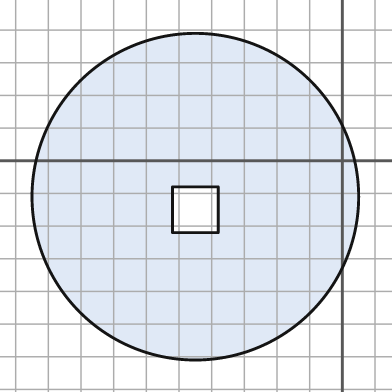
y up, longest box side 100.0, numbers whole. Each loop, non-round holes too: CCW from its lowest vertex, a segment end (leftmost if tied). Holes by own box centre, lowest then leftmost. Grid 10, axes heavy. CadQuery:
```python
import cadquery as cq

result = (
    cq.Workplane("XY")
    .moveTo(-45.0, -11.0)
    .circle(50.0)
    .moveTo(-52.0, -22.0)
    .lineTo(-38.0, -22.0)
    .lineTo(-38.0, -8.0)
    .lineTo(-52.0, -8.0)
    .close()
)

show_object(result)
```